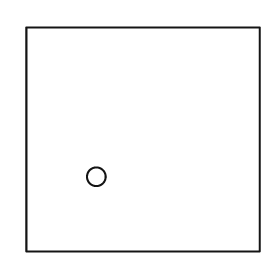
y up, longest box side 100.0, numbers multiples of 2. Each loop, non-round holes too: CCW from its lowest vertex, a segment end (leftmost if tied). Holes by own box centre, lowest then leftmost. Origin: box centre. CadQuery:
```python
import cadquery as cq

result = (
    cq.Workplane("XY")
    .moveTo(-50.0, -48.0)
    .lineTo(50.0, -48.0)
    .lineTo(50.0, 48.0)
    .lineTo(-50.0, 48.0)
    .close()
    .moveTo(-20.0, -16.0)
    .circle(4.0)
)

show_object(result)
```